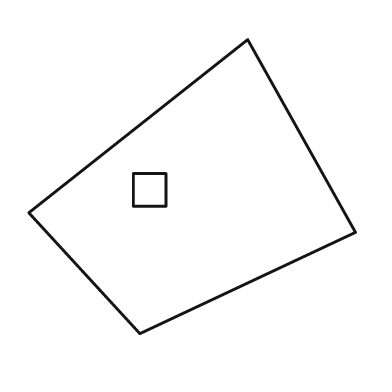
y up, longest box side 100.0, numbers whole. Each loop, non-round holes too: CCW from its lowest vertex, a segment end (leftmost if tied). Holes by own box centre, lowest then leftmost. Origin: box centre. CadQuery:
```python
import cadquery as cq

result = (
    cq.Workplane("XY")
    .moveTo(-16.0, -45.0)
    .lineTo(50.0, -14.0)
    .lineTo(17.0, 45.0)
    .lineTo(-50.0, -8.0)
    .close()
    .moveTo(-18.0, -6.0)
    .lineTo(-8.0, -6.0)
    .lineTo(-8.0, 4.0)
    .lineTo(-18.0, 4.0)
    .close()
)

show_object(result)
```